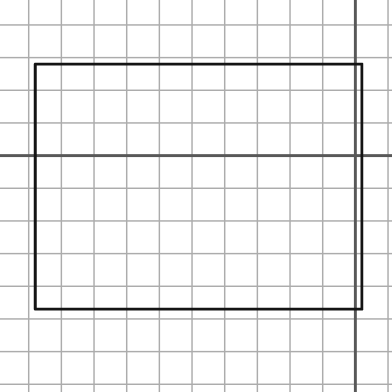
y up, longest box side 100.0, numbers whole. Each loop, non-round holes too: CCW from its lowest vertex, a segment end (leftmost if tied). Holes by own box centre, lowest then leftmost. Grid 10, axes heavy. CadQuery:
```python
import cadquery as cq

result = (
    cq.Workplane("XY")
    .moveTo(-98.0, -47.0)
    .lineTo(2.0, -47.0)
    .lineTo(2.0, 28.0)
    .lineTo(-98.0, 28.0)
    .close()
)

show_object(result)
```